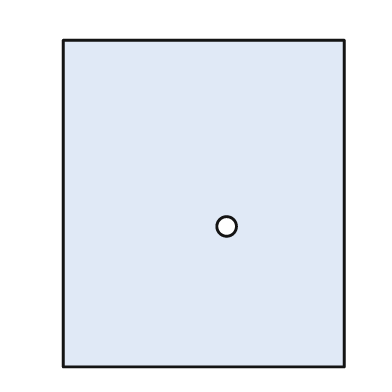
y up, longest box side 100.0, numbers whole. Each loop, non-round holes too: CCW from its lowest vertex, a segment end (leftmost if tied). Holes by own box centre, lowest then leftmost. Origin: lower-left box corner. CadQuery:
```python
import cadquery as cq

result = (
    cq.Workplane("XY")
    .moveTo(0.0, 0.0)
    .lineTo(86.0, 0.0)
    .lineTo(86.0, 100.0)
    .lineTo(0.0, 100.0)
    .close()
    .moveTo(50.0, 43.0)
    .circle(3.0)
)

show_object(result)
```